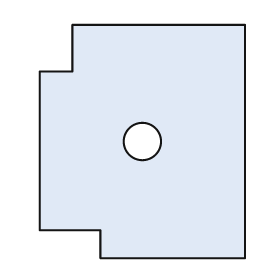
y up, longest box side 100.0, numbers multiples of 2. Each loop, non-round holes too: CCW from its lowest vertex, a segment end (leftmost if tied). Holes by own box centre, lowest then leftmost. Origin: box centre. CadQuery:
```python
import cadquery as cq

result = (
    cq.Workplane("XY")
    .moveTo(-18.0, -50.0)
    .lineTo(44.0, -50.0)
    .lineTo(44.0, 50.0)
    .lineTo(-30.0, 50.0)
    .lineTo(-30.0, 30.0)
    .lineTo(-44.0, 30.0)
    .lineTo(-44.0, -38.0)
    .lineTo(-18.0, -38.0)
    .close()
    .moveTo(0.0, 0.0)
    .circle(8.0)
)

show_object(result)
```